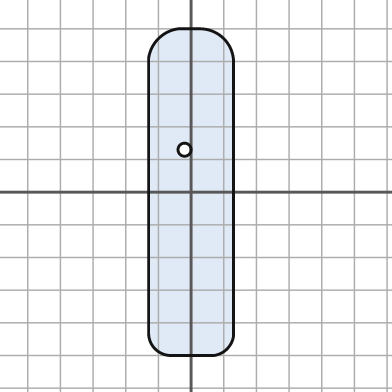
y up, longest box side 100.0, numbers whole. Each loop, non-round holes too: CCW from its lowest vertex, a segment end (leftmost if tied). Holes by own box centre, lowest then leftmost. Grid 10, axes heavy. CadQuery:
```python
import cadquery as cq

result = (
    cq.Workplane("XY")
    .moveTo(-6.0, -50.0)
    .lineTo(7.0, -50.0)
    .threePointArc((11.0, -48.0), (13.0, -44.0))
    .lineTo(13.0, 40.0)
    .threePointArc((10.0, 47.0), (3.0, 50.0))
    .lineTo(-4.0, 50.0)
    .threePointArc((-10.0, 47.0), (-13.0, 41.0))
    .lineTo(-13.0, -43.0)
    .threePointArc((-11.0, -48.0), (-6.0, -50.0))
    .close()
    .moveTo(-2.0, 13.0)
    .circle(2.0)
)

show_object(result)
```